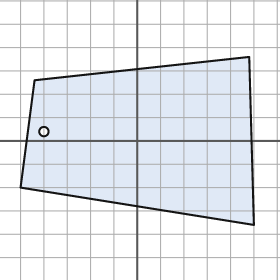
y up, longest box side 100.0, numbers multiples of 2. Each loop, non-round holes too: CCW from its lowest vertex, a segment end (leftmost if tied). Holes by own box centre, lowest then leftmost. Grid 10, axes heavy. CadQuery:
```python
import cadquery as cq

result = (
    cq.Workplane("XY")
    .moveTo(50.0, -36.0)
    .lineTo(48.0, 36.0)
    .lineTo(-44.0, 26.0)
    .lineTo(-50.0, -20.0)
    .close()
    .moveTo(-40.0, 4.0)
    .circle(2.0)
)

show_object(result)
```